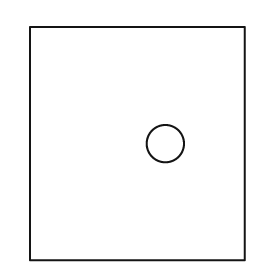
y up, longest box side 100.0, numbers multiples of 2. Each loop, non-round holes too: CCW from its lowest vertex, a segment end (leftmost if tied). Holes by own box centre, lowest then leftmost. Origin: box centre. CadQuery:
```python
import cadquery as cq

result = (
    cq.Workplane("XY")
    .moveTo(-46.0, -50.0)
    .lineTo(46.0, -50.0)
    .lineTo(46.0, 50.0)
    .lineTo(-46.0, 50.0)
    .close()
    .moveTo(12.0, 0.0)
    .circle(8.0)
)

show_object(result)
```